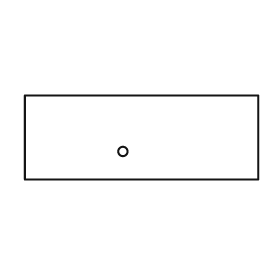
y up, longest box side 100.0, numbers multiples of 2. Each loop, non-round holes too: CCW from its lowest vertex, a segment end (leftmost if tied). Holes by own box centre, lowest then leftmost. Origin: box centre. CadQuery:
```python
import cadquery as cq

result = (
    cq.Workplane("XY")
    .moveTo(-50.0, -18.0)
    .lineTo(50.0, -18.0)
    .lineTo(50.0, 18.0)
    .lineTo(-50.0, 18.0)
    .close()
    .moveTo(-8.0, -6.0)
    .circle(2.0)
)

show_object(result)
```